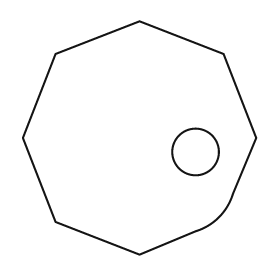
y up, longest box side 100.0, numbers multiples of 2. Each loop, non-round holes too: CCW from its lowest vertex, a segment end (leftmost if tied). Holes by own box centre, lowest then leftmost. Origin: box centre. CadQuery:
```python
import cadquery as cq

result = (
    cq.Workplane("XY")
    .moveTo(0.0, -50.0)
    .lineTo(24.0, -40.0)
    .threePointArc((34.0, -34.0), (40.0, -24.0))
    .lineTo(50.0, 0.0)
    .lineTo(36.0, 36.0)
    .lineTo(0.0, 50.0)
    .lineTo(-36.0, 36.0)
    .lineTo(-50.0, 0.0)
    .lineTo(-36.0, -36.0)
    .close()
    .moveTo(24.0, -6.0)
    .circle(10.0)
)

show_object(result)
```